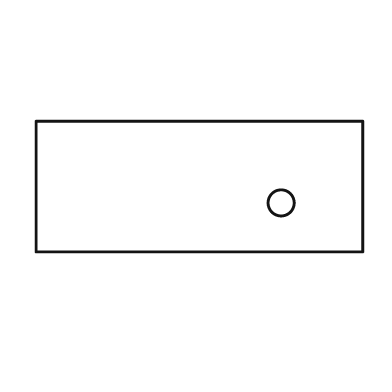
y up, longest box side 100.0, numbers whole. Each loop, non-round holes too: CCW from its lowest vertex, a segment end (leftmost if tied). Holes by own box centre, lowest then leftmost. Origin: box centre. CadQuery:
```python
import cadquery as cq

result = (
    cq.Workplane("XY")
    .moveTo(-50.0, -20.0)
    .lineTo(50.0, -20.0)
    .lineTo(50.0, 20.0)
    .lineTo(-50.0, 20.0)
    .close()
    .moveTo(25.0, -5.0)
    .circle(4.0)
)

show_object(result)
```